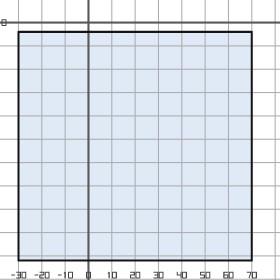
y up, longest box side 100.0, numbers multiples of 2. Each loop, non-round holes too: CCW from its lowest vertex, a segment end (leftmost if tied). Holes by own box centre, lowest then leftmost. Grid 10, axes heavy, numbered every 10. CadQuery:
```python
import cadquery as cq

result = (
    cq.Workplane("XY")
    .moveTo(-30.0, -102.0)
    .lineTo(70.0, -102.0)
    .lineTo(70.0, -4.0)
    .lineTo(-30.0, -4.0)
    .close()
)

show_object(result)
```